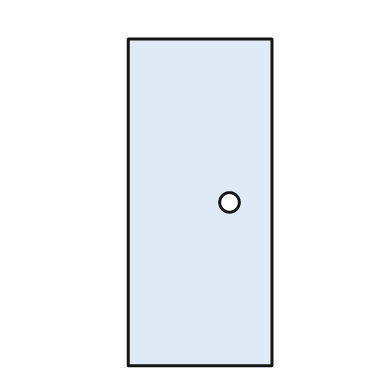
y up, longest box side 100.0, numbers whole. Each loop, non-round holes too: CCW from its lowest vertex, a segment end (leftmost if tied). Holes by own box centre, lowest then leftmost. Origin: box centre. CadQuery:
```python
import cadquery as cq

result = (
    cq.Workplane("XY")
    .moveTo(-22.0, -50.0)
    .lineTo(22.0, -50.0)
    .lineTo(22.0, 50.0)
    .lineTo(-22.0, 50.0)
    .close()
    .moveTo(9.0, 0.0)
    .circle(3.0)
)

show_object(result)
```